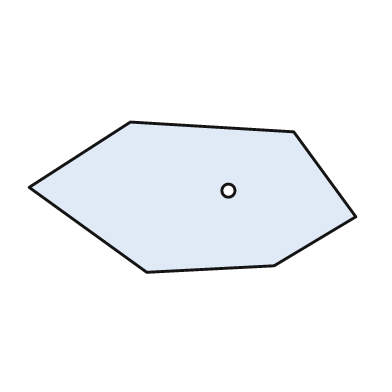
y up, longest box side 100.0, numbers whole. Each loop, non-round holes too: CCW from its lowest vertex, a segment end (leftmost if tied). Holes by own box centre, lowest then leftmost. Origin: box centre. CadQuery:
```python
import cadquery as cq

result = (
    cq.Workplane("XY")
    .moveTo(-14.0, -23.0)
    .lineTo(25.0, -21.0)
    .lineTo(50.0, -6.0)
    .lineTo(31.0, 20.0)
    .lineTo(-19.0, 23.0)
    .lineTo(-50.0, 3.0)
    .close()
    .moveTo(11.0, 2.0)
    .circle(2.0)
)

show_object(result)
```